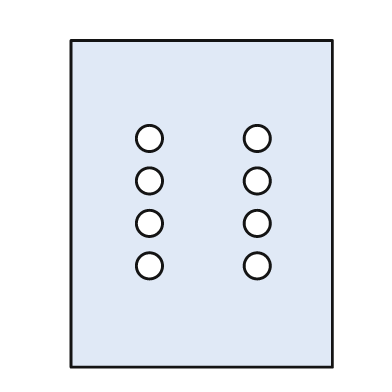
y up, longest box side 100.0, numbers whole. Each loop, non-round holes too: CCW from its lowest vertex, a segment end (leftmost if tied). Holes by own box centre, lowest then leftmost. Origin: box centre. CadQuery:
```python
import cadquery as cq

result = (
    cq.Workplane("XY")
    .moveTo(-40.0, -50.0)
    .lineTo(40.0, -50.0)
    .lineTo(40.0, 50.0)
    .lineTo(-40.0, 50.0)
    .close()
    .moveTo(-16.0, -19.0)
    .circle(4.0)
    .moveTo(17.0, -19.0)
    .circle(4.0)
    .moveTo(-16.0, -6.0)
    .circle(4.0)
    .moveTo(17.0, -6.0)
    .circle(4.0)
    .moveTo(-16.0, 7.0)
    .circle(4.0)
    .moveTo(17.0, 7.0)
    .circle(4.0)
    .moveTo(-16.0, 20.0)
    .circle(4.0)
    .moveTo(17.0, 20.0)
    .circle(4.0)
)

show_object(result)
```